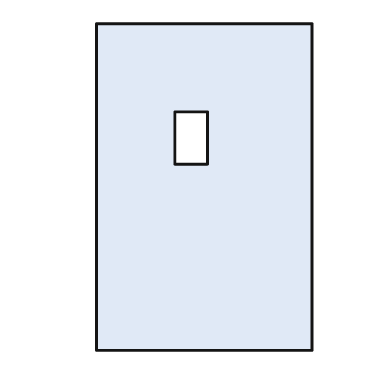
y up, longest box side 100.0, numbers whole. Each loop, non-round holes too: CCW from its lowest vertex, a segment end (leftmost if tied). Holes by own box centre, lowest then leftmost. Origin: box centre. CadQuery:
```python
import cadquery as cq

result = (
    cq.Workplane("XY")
    .moveTo(-33.0, -50.0)
    .lineTo(33.0, -50.0)
    .lineTo(33.0, 50.0)
    .lineTo(-33.0, 50.0)
    .close()
    .moveTo(-9.0, 7.0)
    .lineTo(1.0, 7.0)
    .lineTo(1.0, 23.0)
    .lineTo(-9.0, 23.0)
    .close()
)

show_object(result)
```